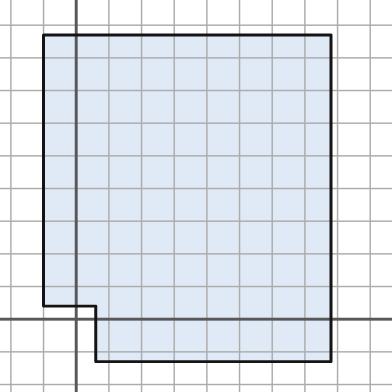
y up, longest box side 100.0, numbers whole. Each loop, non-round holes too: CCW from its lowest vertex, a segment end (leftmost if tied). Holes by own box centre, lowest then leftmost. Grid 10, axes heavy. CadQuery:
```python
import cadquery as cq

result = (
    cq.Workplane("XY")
    .moveTo(6.0, -13.0)
    .lineTo(78.0, -13.0)
    .lineTo(78.0, 87.0)
    .lineTo(-10.0, 87.0)
    .lineTo(-10.0, 4.0)
    .lineTo(6.0, 4.0)
    .close()
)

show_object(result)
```